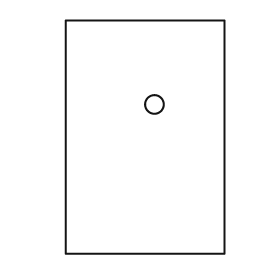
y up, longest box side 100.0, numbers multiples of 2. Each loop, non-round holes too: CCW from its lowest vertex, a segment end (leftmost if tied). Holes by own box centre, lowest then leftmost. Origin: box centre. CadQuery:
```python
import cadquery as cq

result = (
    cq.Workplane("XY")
    .moveTo(-34.0, -50.0)
    .lineTo(34.0, -50.0)
    .lineTo(34.0, 50.0)
    .lineTo(-34.0, 50.0)
    .close()
    .moveTo(4.0, 14.0)
    .circle(4.0)
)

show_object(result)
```